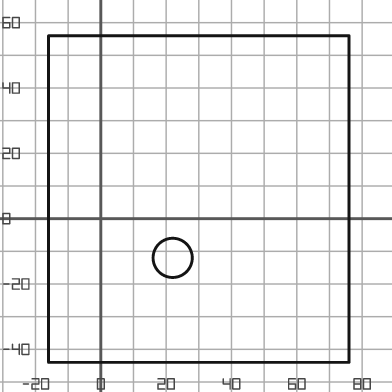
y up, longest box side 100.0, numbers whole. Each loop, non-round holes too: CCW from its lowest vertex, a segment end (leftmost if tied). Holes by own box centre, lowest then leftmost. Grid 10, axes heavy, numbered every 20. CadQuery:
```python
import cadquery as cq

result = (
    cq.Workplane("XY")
    .moveTo(-16.0, -44.0)
    .lineTo(76.0, -44.0)
    .lineTo(76.0, 56.0)
    .lineTo(-16.0, 56.0)
    .close()
    .moveTo(22.0, -12.0)
    .circle(6.0)
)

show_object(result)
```